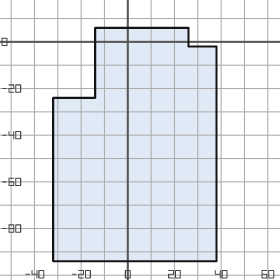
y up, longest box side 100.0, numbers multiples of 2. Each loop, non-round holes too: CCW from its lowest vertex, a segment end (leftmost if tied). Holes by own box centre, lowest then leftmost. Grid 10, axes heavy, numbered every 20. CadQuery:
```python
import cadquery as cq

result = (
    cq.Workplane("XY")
    .moveTo(-32.0, -94.0)
    .lineTo(38.0, -94.0)
    .lineTo(38.0, -2.0)
    .lineTo(26.0, -2.0)
    .lineTo(26.0, 6.0)
    .lineTo(-14.0, 6.0)
    .lineTo(-14.0, -24.0)
    .lineTo(-32.0, -24.0)
    .close()
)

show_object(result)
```